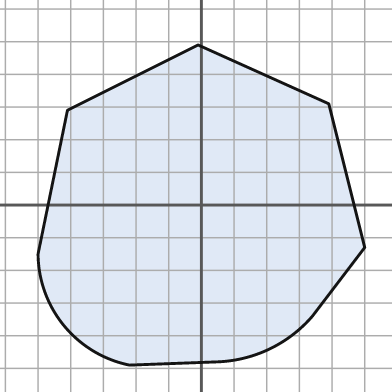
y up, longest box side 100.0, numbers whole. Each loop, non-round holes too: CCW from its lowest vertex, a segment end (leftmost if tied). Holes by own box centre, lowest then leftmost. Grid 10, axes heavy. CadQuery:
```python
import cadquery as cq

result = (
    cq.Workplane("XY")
    .moveTo(-22.0, -49.0)
    .lineTo(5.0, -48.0)
    .threePointArc((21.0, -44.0), (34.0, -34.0))
    .lineTo(50.0, -13.0)
    .lineTo(39.0, 31.0)
    .lineTo(-1.0, 49.0)
    .lineTo(-41.0, 29.0)
    .lineTo(-50.0, -15.0)
    .threePointArc((-42.0, -37.0), (-22.0, -49.0))
    .close()
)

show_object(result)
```